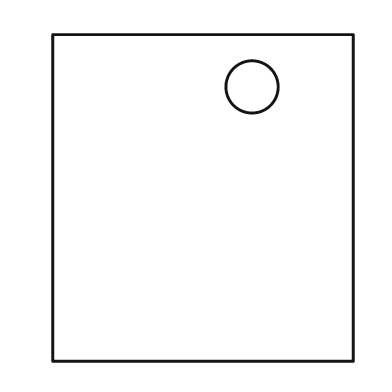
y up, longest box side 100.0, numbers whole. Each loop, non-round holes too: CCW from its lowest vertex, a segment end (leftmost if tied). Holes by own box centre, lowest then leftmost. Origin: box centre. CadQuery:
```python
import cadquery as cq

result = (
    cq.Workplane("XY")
    .moveTo(-46.0, -50.0)
    .lineTo(46.0, -50.0)
    .lineTo(46.0, 50.0)
    .lineTo(-46.0, 50.0)
    .close()
    .moveTo(15.0, 34.0)
    .circle(8.0)
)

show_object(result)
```